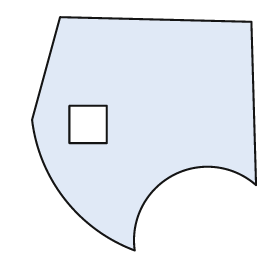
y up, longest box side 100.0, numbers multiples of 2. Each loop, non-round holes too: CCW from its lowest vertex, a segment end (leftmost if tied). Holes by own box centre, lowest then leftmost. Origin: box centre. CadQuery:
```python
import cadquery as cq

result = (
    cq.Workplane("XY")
    .moveTo(-4.0, -50.0)
    .threePointArc((12.0, -18.0), (48.0, -22.0))
    .lineTo(46.0, 48.0)
    .lineTo(-36.0, 50.0)
    .lineTo(-48.0, 6.0)
    .threePointArc((-34.0, -28.0), (-4.0, -50.0))
    .close()
    .moveTo(-32.0, -4.0)
    .lineTo(-16.0, -4.0)
    .lineTo(-16.0, 12.0)
    .lineTo(-32.0, 12.0)
    .close()
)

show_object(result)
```